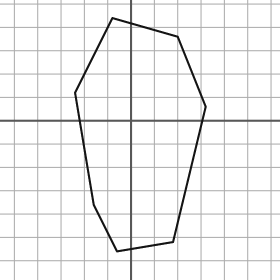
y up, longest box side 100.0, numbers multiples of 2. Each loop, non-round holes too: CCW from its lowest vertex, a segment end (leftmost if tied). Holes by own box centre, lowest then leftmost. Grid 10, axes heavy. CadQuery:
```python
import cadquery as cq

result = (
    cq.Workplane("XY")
    .moveTo(-6.0, -56.0)
    .lineTo(18.0, -52.0)
    .lineTo(32.0, 6.0)
    .lineTo(20.0, 36.0)
    .lineTo(-8.0, 44.0)
    .lineTo(-24.0, 12.0)
    .lineTo(-16.0, -36.0)
    .close()
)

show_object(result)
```